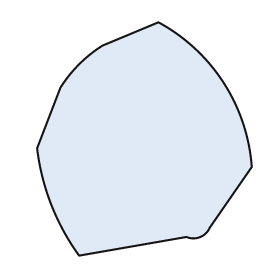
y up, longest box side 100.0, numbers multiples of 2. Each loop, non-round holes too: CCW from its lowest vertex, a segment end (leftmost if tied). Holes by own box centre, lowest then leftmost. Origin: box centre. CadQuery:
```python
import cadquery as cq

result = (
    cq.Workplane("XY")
    .moveTo(-28.0, -50.0)
    .lineTo(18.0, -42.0)
    .threePointArc((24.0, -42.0), (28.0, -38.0))
    .lineTo(46.0, -12.0)
    .threePointArc((34.0, 24.0), (6.0, 50.0))
    .lineTo(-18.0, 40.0)
    .threePointArc((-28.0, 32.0), (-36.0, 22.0))
    .lineTo(-46.0, -4.0)
    .threePointArc((-40.0, -28.0), (-28.0, -50.0))
    .close()
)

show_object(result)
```